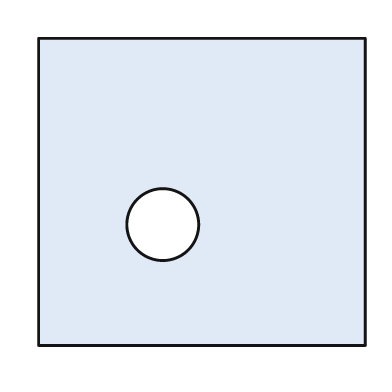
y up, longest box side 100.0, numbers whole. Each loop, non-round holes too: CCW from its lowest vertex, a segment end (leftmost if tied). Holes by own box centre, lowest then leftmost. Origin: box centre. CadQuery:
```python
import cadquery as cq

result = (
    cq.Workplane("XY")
    .moveTo(-50.0, -47.0)
    .lineTo(50.0, -47.0)
    .lineTo(50.0, 47.0)
    .lineTo(-50.0, 47.0)
    .close()
    .moveTo(-12.0, -10.0)
    .circle(11.0)
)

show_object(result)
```